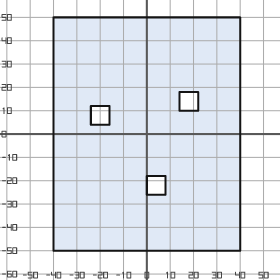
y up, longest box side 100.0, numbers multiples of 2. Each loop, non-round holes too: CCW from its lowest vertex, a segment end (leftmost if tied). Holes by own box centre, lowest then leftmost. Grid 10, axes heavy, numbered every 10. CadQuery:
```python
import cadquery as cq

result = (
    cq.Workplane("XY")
    .moveTo(-40.0, -50.0)
    .lineTo(40.0, -50.0)
    .lineTo(40.0, 50.0)
    .lineTo(-40.0, 50.0)
    .close()
    .moveTo(0.0, -26.0)
    .lineTo(8.0, -26.0)
    .lineTo(8.0, -18.0)
    .lineTo(0.0, -18.0)
    .close()
    .moveTo(-24.0, 4.0)
    .lineTo(-16.0, 4.0)
    .lineTo(-16.0, 12.0)
    .lineTo(-24.0, 12.0)
    .close()
    .moveTo(14.0, 10.0)
    .lineTo(22.0, 10.0)
    .lineTo(22.0, 18.0)
    .lineTo(14.0, 18.0)
    .close()
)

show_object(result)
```